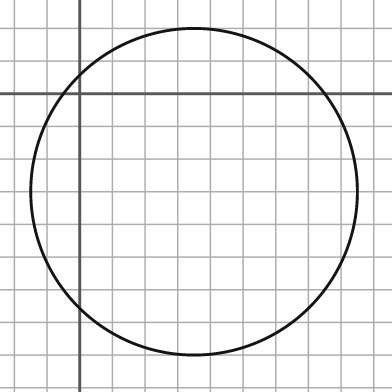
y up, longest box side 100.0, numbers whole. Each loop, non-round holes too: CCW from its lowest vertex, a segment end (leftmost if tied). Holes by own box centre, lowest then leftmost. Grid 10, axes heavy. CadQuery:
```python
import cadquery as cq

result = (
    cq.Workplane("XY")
    .moveTo(35.0, -30.0)
    .circle(50.0)
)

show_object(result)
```